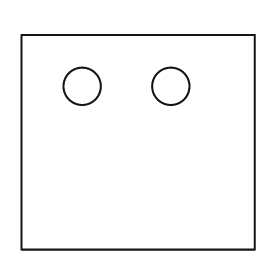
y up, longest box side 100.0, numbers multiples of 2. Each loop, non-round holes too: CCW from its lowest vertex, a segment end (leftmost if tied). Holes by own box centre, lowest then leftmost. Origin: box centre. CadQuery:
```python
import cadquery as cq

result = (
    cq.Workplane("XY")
    .moveTo(-50.0, -46.0)
    .lineTo(50.0, -46.0)
    .lineTo(50.0, 46.0)
    .lineTo(-50.0, 46.0)
    .close()
    .moveTo(-24.0, 24.0)
    .circle(8.0)
    .moveTo(14.0, 24.0)
    .circle(8.0)
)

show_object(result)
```